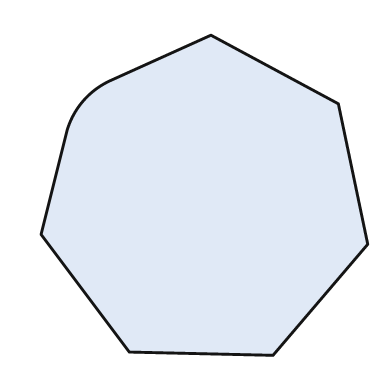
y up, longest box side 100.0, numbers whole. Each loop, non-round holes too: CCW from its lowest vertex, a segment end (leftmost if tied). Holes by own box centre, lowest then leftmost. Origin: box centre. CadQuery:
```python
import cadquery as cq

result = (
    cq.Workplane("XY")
    .moveTo(21.0, -49.0)
    .lineTo(50.0, -15.0)
    .lineTo(41.0, 28.0)
    .lineTo(2.0, 49.0)
    .lineTo(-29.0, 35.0)
    .threePointArc((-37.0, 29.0), (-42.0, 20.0))
    .lineTo(-50.0, -12.0)
    .lineTo(-23.0, -48.0)
    .close()
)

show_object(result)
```